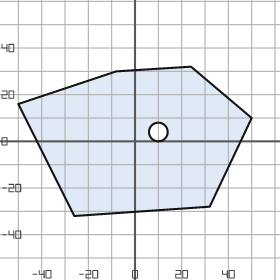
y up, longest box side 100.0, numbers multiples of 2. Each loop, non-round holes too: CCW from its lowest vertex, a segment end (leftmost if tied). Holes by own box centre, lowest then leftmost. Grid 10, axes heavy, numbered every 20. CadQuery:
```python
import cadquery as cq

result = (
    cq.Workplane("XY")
    .moveTo(-26.0, -32.0)
    .lineTo(32.0, -28.0)
    .lineTo(50.0, 10.0)
    .lineTo(24.0, 32.0)
    .lineTo(-8.0, 30.0)
    .lineTo(-50.0, 16.0)
    .close()
    .moveTo(10.0, 4.0)
    .circle(4.0)
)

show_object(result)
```